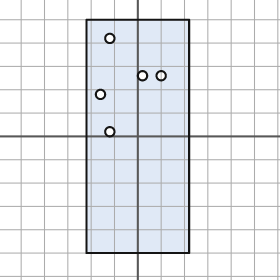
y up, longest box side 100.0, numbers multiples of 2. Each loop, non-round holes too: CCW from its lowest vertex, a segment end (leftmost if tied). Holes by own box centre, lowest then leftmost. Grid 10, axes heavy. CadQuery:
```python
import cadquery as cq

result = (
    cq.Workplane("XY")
    .moveTo(-22.0, -50.0)
    .lineTo(22.0, -50.0)
    .lineTo(22.0, 50.0)
    .lineTo(-22.0, 50.0)
    .close()
    .moveTo(-12.0, 2.0)
    .circle(2.0)
    .moveTo(-16.0, 18.0)
    .circle(2.0)
    .moveTo(2.0, 26.0)
    .circle(2.0)
    .moveTo(10.0, 26.0)
    .circle(2.0)
    .moveTo(-12.0, 42.0)
    .circle(2.0)
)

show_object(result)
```